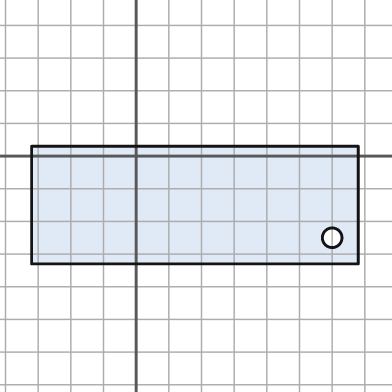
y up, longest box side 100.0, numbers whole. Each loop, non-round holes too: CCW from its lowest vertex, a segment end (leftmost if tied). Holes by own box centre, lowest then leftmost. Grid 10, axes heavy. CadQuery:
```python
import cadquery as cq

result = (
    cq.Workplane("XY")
    .moveTo(-32.0, -33.0)
    .lineTo(68.0, -33.0)
    .lineTo(68.0, 3.0)
    .lineTo(-32.0, 3.0)
    .close()
    .moveTo(60.0, -25.0)
    .circle(3.0)
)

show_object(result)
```